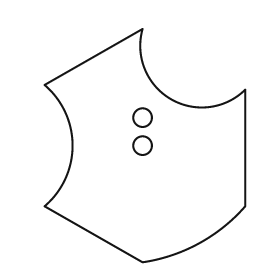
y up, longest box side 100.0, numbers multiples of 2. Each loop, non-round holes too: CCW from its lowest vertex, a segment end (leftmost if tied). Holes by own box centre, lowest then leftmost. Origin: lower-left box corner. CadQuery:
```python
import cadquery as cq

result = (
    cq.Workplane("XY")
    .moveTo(42.0, 0.0)
    .threePointArc((66.0, 8.0), (86.0, 24.0))
    .lineTo(86.0, 74.0)
    .threePointArc((54.0, 70.0), (42.0, 100.0))
    .lineTo(0.0, 76.0)
    .threePointArc((12.0, 50.0), (0.0, 24.0))
    .close()
    .moveTo(42.0, 50.0)
    .circle(4.0)
    .moveTo(42.0, 62.0)
    .circle(4.0)
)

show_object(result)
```